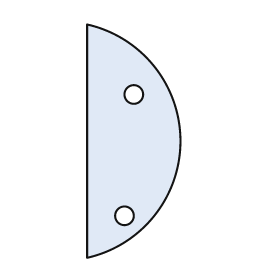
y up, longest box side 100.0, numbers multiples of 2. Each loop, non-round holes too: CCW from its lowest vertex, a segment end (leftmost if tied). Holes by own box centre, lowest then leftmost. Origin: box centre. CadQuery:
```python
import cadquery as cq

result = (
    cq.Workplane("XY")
    .moveTo(-20.0, -50.0)
    .threePointArc((20.0, 0.0), (-20.0, 50.0))
    .close()
    .moveTo(-4.0, -32.0)
    .circle(4.0)
    .moveTo(0.0, 20.0)
    .circle(4.0)
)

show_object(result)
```